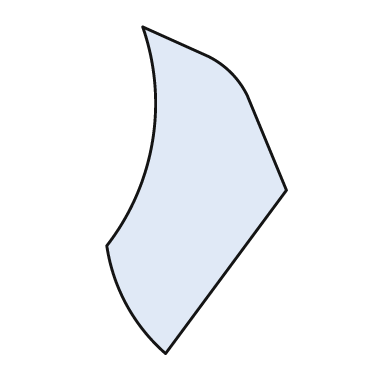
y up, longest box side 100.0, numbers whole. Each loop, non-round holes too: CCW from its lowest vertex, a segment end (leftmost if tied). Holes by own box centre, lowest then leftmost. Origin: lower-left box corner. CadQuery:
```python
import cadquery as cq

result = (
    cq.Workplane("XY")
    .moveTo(18.0, 0.0)
    .lineTo(55.0, 50.0)
    .lineTo(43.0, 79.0)
    .threePointArc((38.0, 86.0), (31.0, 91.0))
    .lineTo(11.0, 100.0)
    .threePointArc((14.0, 65.0), (0.0, 33.0))
    .threePointArc((6.0, 15.0), (18.0, 0.0))
    .close()
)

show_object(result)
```